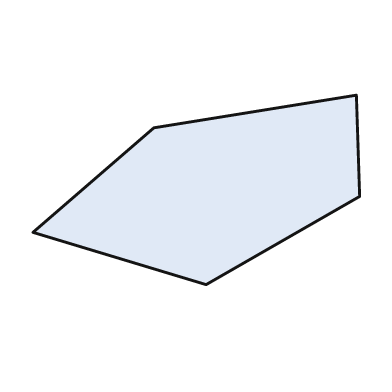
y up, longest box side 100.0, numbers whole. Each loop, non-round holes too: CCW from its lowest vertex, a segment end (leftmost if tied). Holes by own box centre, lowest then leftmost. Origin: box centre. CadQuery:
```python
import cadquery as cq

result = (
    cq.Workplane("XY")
    .moveTo(3.0, -29.0)
    .lineTo(50.0, -2.0)
    .lineTo(49.0, 29.0)
    .lineTo(-13.0, 19.0)
    .lineTo(-50.0, -13.0)
    .close()
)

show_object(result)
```